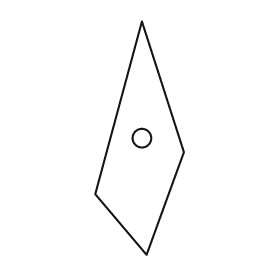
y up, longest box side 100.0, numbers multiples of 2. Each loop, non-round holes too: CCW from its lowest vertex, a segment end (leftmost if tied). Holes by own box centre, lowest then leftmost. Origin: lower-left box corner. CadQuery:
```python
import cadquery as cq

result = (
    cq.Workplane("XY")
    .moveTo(22.0, 0.0)
    .lineTo(38.0, 44.0)
    .lineTo(20.0, 100.0)
    .lineTo(0.0, 26.0)
    .close()
    .moveTo(20.0, 50.0)
    .circle(4.0)
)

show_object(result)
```